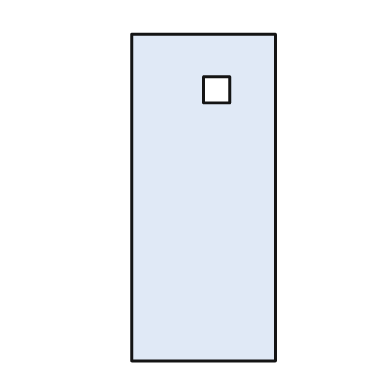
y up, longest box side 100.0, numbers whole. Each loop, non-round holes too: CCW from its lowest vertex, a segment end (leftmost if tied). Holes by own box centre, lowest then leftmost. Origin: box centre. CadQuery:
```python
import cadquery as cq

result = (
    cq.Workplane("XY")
    .moveTo(-22.0, -50.0)
    .lineTo(22.0, -50.0)
    .lineTo(22.0, 50.0)
    .lineTo(-22.0, 50.0)
    .close()
    .moveTo(0.0, 29.0)
    .lineTo(8.0, 29.0)
    .lineTo(8.0, 37.0)
    .lineTo(0.0, 37.0)
    .close()
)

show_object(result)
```